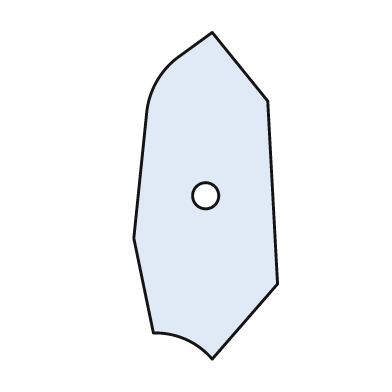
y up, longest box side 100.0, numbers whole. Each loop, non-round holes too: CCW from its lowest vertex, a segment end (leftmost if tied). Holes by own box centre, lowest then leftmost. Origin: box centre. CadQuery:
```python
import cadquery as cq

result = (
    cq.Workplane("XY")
    .moveTo(2.0, -50.0)
    .lineTo(22.0, -27.0)
    .lineTo(19.0, 29.0)
    .lineTo(2.0, 50.0)
    .lineTo(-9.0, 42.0)
    .threePointArc((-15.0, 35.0), (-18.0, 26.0))
    .lineTo(-22.0, -13.0)
    .lineTo(-16.0, -42.0)
    .threePointArc((-6.0, -44.0), (2.0, -50.0))
    .close()
    .moveTo(0.0, 0.0)
    .circle(4.0)
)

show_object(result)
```